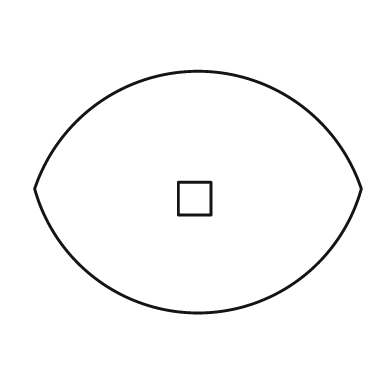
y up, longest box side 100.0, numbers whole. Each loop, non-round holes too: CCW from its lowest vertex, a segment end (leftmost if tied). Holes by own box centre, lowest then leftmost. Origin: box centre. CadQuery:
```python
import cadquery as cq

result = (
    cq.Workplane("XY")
    .moveTo(-50.0, 1.0)
    .threePointArc((0.0, -37.0), (50.0, 1.0))
    .threePointArc((0.0, 37.0), (-50.0, 1.0))
    .close()
    .moveTo(-6.0, -7.0)
    .lineTo(4.0, -7.0)
    .lineTo(4.0, 3.0)
    .lineTo(-6.0, 3.0)
    .close()
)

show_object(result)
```